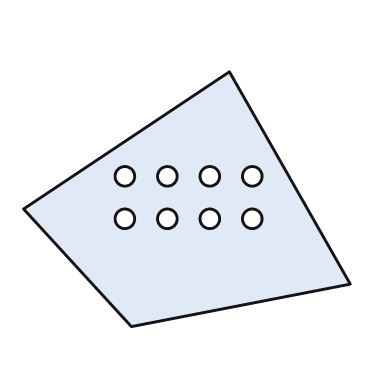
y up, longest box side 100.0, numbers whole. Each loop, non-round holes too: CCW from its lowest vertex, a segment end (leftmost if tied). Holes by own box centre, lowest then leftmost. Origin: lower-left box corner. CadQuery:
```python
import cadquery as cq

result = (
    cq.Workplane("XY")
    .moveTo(33.0, 0.0)
    .lineTo(100.0, 13.0)
    .lineTo(63.0, 78.0)
    .lineTo(0.0, 36.0)
    .close()
    .moveTo(31.0, 33.0)
    .circle(3.0)
    .moveTo(44.0, 33.0)
    .circle(3.0)
    .moveTo(57.0, 33.0)
    .circle(3.0)
    .moveTo(70.0, 33.0)
    .circle(3.0)
    .moveTo(31.0, 46.0)
    .circle(3.0)
    .moveTo(44.0, 46.0)
    .circle(3.0)
    .moveTo(57.0, 46.0)
    .circle(3.0)
    .moveTo(70.0, 46.0)
    .circle(3.0)
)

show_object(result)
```